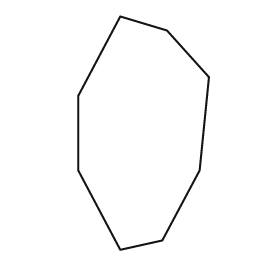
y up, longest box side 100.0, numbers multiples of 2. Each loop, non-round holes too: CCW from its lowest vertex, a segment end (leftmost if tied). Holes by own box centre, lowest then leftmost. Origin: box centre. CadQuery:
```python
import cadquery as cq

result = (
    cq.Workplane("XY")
    .moveTo(-10.0, -50.0)
    .lineTo(8.0, -46.0)
    .lineTo(24.0, -16.0)
    .lineTo(28.0, 24.0)
    .lineTo(10.0, 44.0)
    .lineTo(-10.0, 50.0)
    .lineTo(-28.0, 16.0)
    .lineTo(-28.0, -16.0)
    .close()
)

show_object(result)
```